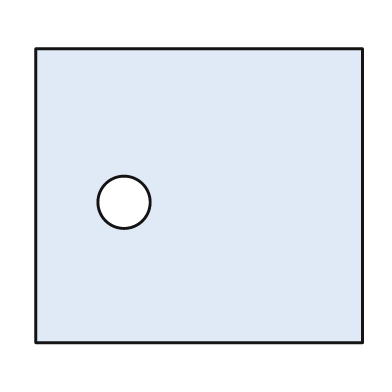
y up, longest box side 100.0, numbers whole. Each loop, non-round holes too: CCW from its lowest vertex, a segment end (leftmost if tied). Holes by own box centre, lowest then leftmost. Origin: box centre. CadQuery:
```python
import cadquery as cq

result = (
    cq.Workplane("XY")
    .moveTo(-50.0, -45.0)
    .lineTo(50.0, -45.0)
    .lineTo(50.0, 45.0)
    .lineTo(-50.0, 45.0)
    .close()
    .moveTo(-23.0, -2.0)
    .circle(8.0)
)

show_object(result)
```